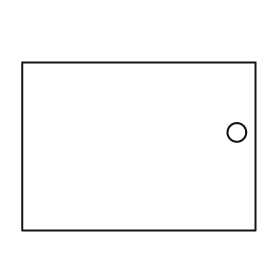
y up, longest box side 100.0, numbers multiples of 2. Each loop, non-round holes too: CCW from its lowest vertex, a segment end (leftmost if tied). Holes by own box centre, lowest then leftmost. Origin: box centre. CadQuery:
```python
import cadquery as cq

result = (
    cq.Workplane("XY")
    .moveTo(-50.0, -36.0)
    .lineTo(50.0, -36.0)
    .lineTo(50.0, 36.0)
    .lineTo(-50.0, 36.0)
    .close()
    .moveTo(42.0, 6.0)
    .circle(4.0)
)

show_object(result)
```